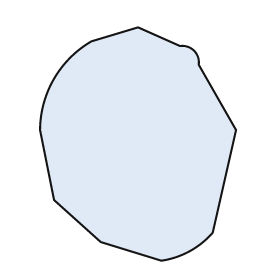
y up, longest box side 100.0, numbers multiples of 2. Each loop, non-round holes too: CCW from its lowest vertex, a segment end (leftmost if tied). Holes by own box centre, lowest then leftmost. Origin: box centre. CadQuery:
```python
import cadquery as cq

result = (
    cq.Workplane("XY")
    .moveTo(10.0, -50.0)
    .threePointArc((22.0, -46.0), (32.0, -38.0))
    .lineTo(42.0, 6.0)
    .lineTo(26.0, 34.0)
    .threePointArc((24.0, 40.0), (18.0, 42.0))
    .lineTo(0.0, 50.0)
    .lineTo(-20.0, 44.0)
    .threePointArc((-36.0, 28.0), (-42.0, 6.0))
    .lineTo(-36.0, -24.0)
    .lineTo(-16.0, -42.0)
    .close()
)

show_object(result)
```